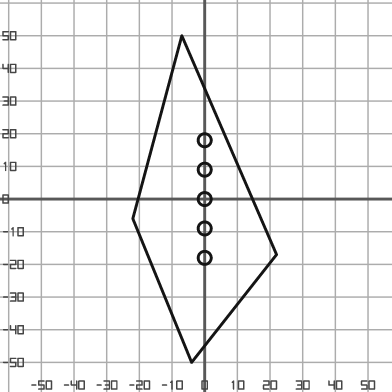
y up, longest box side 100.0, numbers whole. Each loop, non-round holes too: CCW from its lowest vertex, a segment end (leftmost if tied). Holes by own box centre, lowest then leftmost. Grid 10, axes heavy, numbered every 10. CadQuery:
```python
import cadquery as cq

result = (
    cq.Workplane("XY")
    .moveTo(-4.0, -50.0)
    .lineTo(22.0, -17.0)
    .lineTo(-7.0, 50.0)
    .lineTo(-22.0, -6.0)
    .close()
    .moveTo(0.0, -18.0)
    .circle(2.0)
    .moveTo(0.0, -9.0)
    .circle(2.0)
    .moveTo(0.0, 0.0)
    .circle(2.0)
    .moveTo(0.0, 9.0)
    .circle(2.0)
    .moveTo(0.0, 18.0)
    .circle(2.0)
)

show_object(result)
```